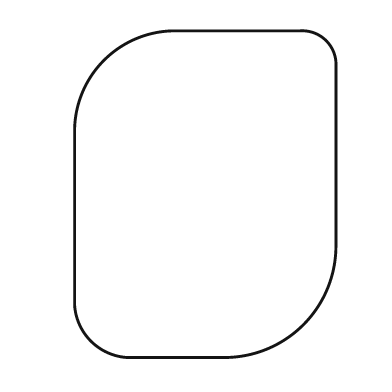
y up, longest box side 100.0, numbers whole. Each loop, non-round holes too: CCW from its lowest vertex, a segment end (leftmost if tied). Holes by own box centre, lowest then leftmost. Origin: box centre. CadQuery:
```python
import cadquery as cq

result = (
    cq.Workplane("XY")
    .moveTo(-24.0, -50.0)
    .lineTo(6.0, -50.0)
    .threePointArc((30.0, -40.0), (40.0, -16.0))
    .lineTo(40.0, 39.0)
    .threePointArc((37.0, 47.0), (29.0, 50.0))
    .lineTo(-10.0, 50.0)
    .threePointArc((-31.0, 41.0), (-40.0, 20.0))
    .lineTo(-40.0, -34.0)
    .threePointArc((-35.0, -45.0), (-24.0, -50.0))
    .close()
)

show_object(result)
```